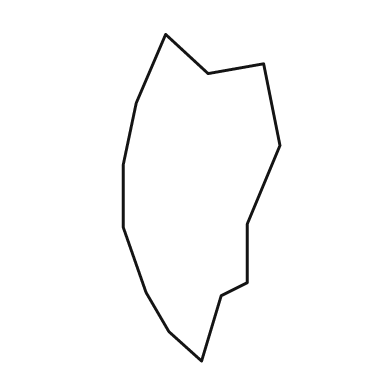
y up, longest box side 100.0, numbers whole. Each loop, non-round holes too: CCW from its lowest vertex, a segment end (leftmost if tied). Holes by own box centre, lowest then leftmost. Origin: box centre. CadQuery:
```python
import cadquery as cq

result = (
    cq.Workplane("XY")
    .moveTo(0.0, -50.0)
    .lineTo(6.0, -30.0)
    .lineTo(14.0, -26.0)
    .lineTo(14.0, -8.0)
    .lineTo(24.0, 16.0)
    .lineTo(19.0, 41.0)
    .lineTo(2.0, 38.0)
    .lineTo(-11.0, 50.0)
    .lineTo(-20.0, 29.0)
    .lineTo(-24.0, 10.0)
    .lineTo(-24.0, -9.0)
    .lineTo(-17.0, -29.0)
    .lineTo(-10.0, -41.0)
    .close()
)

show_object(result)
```